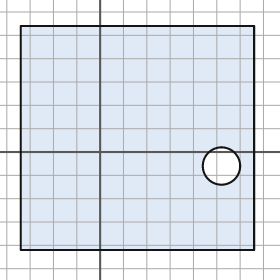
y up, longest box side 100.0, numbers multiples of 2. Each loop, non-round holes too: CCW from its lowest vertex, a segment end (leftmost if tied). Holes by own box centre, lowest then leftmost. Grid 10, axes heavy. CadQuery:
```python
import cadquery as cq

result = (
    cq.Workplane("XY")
    .moveTo(-34.0, -42.0)
    .lineTo(66.0, -42.0)
    .lineTo(66.0, 54.0)
    .lineTo(-34.0, 54.0)
    .close()
    .moveTo(52.0, -6.0)
    .circle(8.0)
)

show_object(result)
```